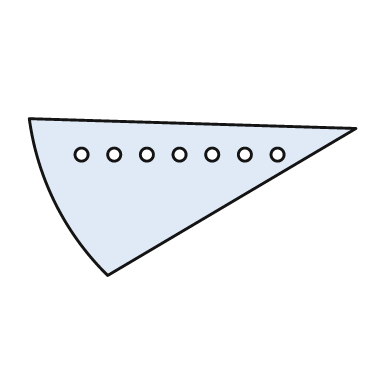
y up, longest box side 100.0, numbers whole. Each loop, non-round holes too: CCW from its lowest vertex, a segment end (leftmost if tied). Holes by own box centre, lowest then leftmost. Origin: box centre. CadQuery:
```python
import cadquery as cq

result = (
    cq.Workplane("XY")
    .moveTo(-26.0, -24.0)
    .lineTo(50.0, 21.0)
    .lineTo(-50.0, 24.0)
    .threePointArc((-42.0, -2.0), (-26.0, -24.0))
    .close()
    .moveTo(-34.0, 13.0)
    .circle(2.0)
    .moveTo(-24.0, 13.0)
    .circle(2.0)
    .moveTo(-14.0, 13.0)
    .circle(2.0)
    .moveTo(-4.0, 13.0)
    .circle(2.0)
    .moveTo(6.0, 13.0)
    .circle(2.0)
    .moveTo(16.0, 13.0)
    .circle(2.0)
    .moveTo(26.0, 13.0)
    .circle(2.0)
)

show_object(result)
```